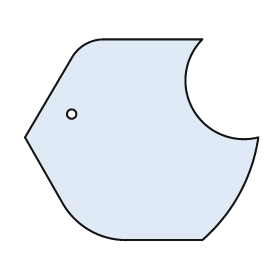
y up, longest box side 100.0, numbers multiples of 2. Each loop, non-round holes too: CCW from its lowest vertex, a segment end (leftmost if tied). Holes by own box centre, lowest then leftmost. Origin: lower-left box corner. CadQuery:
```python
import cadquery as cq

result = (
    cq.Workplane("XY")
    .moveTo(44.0, 0.0)
    .lineTo(76.0, 0.0)
    .threePointArc((92.0, 20.0), (100.0, 44.0))
    .threePointArc((72.0, 56.0), (76.0, 86.0))
    .lineTo(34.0, 86.0)
    .threePointArc((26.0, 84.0), (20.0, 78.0))
    .lineTo(0.0, 44.0)
    .lineTo(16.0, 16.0)
    .threePointArc((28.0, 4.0), (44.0, 0.0))
    .close()
    .moveTo(20.0, 54.0)
    .circle(2.0)
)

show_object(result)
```